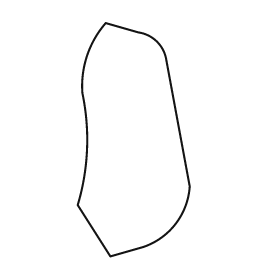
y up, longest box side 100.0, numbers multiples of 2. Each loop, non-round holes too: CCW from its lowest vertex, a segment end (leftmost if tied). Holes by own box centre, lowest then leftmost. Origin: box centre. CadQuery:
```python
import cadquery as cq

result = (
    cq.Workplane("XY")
    .moveTo(-10.0, -50.0)
    .lineTo(4.0, -46.0)
    .threePointArc((18.0, -36.0), (24.0, -20.0))
    .lineTo(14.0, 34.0)
    .threePointArc((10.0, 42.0), (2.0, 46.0))
    .lineTo(-12.0, 50.0)
    .threePointArc((-20.0, 36.0), (-22.0, 20.0))
    .threePointArc((-20.0, -4.0), (-24.0, -28.0))
    .close()
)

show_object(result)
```